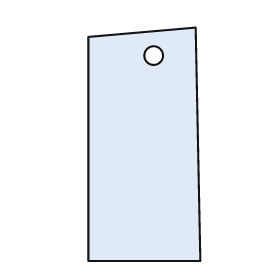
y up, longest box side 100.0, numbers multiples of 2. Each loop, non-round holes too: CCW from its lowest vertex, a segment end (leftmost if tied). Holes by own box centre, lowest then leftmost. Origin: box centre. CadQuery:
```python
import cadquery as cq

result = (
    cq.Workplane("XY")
    .moveTo(-24.0, -50.0)
    .lineTo(24.0, -50.0)
    .lineTo(22.0, 50.0)
    .lineTo(-24.0, 46.0)
    .close()
    .moveTo(4.0, 38.0)
    .circle(4.0)
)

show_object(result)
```